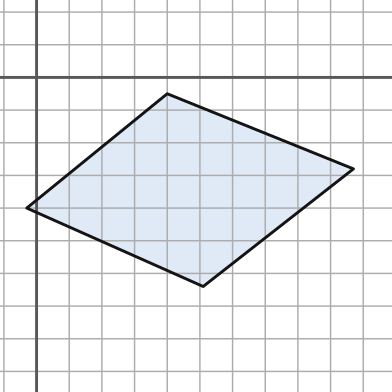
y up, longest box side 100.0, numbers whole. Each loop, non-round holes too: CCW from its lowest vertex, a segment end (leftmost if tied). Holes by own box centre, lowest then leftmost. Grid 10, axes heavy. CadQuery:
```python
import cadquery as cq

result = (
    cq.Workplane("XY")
    .moveTo(51.0, -64.0)
    .lineTo(97.0, -28.0)
    .lineTo(40.0, -5.0)
    .lineTo(-3.0, -40.0)
    .close()
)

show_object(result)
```